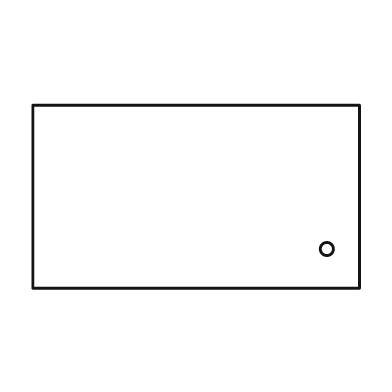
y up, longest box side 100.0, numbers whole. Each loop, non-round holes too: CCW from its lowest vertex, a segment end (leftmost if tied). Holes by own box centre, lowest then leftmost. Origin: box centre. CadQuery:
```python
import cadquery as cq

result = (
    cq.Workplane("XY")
    .moveTo(-50.0, -28.0)
    .lineTo(50.0, -28.0)
    .lineTo(50.0, 28.0)
    .lineTo(-50.0, 28.0)
    .close()
    .moveTo(40.0, -16.0)
    .circle(2.0)
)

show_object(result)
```